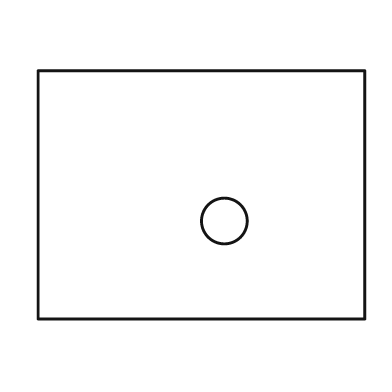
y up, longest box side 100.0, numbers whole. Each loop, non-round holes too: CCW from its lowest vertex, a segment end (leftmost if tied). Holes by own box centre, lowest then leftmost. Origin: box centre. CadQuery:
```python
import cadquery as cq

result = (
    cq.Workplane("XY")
    .moveTo(-50.0, -38.0)
    .lineTo(50.0, -38.0)
    .lineTo(50.0, 38.0)
    .lineTo(-50.0, 38.0)
    .close()
    .moveTo(7.0, -8.0)
    .circle(7.0)
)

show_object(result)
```